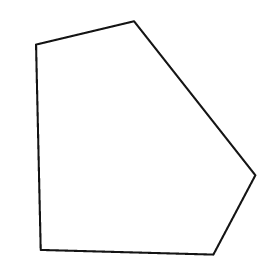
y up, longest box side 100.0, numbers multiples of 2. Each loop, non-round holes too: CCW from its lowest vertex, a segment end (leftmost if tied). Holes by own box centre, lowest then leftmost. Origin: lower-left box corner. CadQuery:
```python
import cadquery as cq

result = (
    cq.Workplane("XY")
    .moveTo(76.0, 0.0)
    .lineTo(94.0, 34.0)
    .lineTo(42.0, 100.0)
    .lineTo(0.0, 90.0)
    .lineTo(2.0, 2.0)
    .close()
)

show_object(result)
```